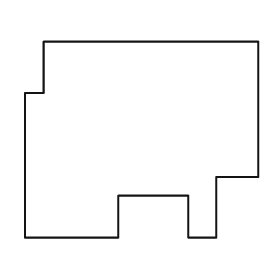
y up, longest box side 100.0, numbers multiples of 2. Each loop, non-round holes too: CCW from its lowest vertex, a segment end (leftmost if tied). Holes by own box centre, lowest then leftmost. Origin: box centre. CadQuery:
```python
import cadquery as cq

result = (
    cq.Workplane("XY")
    .moveTo(-50.0, -42.0)
    .lineTo(-10.0, -42.0)
    .lineTo(-10.0, -24.0)
    .lineTo(20.0, -24.0)
    .lineTo(20.0, -42.0)
    .lineTo(32.0, -42.0)
    .lineTo(32.0, -16.0)
    .lineTo(50.0, -16.0)
    .lineTo(50.0, 42.0)
    .lineTo(-42.0, 42.0)
    .lineTo(-42.0, 20.0)
    .lineTo(-50.0, 20.0)
    .close()
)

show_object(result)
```